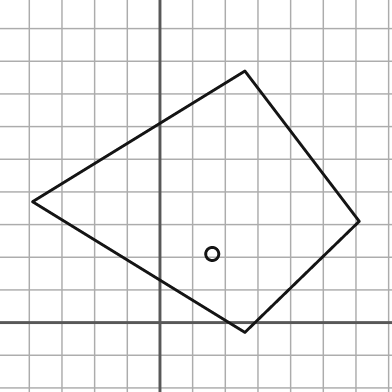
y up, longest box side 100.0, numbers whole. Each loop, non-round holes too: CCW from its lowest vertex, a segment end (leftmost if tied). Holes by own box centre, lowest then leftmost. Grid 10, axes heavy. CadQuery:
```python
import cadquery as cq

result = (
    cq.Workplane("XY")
    .moveTo(26.0, -3.0)
    .lineTo(61.0, 31.0)
    .lineTo(26.0, 77.0)
    .lineTo(-39.0, 37.0)
    .close()
    .moveTo(16.0, 21.0)
    .circle(2.0)
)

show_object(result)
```